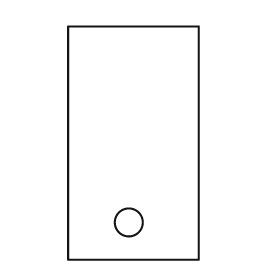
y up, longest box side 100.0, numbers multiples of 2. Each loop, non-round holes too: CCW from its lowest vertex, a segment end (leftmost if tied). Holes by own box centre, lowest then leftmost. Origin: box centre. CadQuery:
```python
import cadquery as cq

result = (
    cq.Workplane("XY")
    .moveTo(-28.0, -50.0)
    .lineTo(28.0, -50.0)
    .lineTo(28.0, 50.0)
    .lineTo(-28.0, 50.0)
    .close()
    .moveTo(-2.0, -34.0)
    .circle(6.0)
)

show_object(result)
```